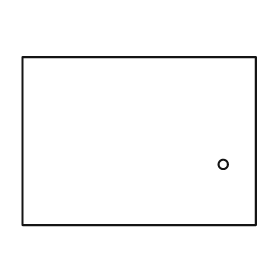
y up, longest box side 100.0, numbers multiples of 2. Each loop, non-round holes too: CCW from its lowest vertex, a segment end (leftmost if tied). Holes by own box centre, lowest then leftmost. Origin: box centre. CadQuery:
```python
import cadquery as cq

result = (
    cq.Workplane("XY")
    .moveTo(-50.0, -36.0)
    .lineTo(50.0, -36.0)
    .lineTo(50.0, 36.0)
    .lineTo(-50.0, 36.0)
    .close()
    .moveTo(36.0, -10.0)
    .circle(2.0)
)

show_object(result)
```